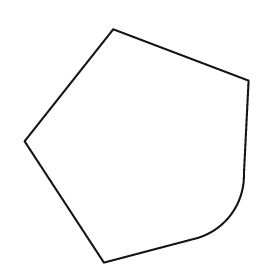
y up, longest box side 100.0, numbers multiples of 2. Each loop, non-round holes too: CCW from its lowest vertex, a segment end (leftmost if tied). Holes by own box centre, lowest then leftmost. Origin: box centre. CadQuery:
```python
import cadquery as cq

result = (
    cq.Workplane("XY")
    .moveTo(-14.0, -50.0)
    .lineTo(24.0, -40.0)
    .threePointArc((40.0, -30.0), (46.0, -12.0))
    .lineTo(48.0, 28.0)
    .lineTo(-10.0, 50.0)
    .lineTo(-48.0, 2.0)
    .close()
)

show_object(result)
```